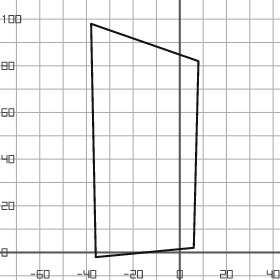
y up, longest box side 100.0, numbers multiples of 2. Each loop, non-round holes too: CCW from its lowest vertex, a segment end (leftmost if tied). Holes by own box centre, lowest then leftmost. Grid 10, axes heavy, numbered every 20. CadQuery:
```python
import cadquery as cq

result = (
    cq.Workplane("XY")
    .moveTo(-36.0, -2.0)
    .lineTo(6.0, 2.0)
    .lineTo(8.0, 82.0)
    .lineTo(-38.0, 98.0)
    .close()
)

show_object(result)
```